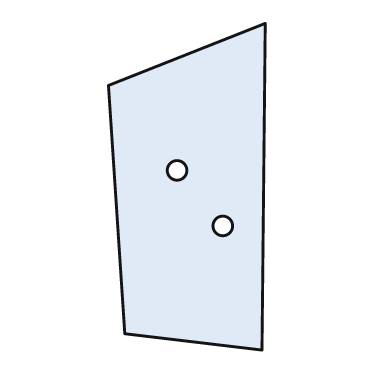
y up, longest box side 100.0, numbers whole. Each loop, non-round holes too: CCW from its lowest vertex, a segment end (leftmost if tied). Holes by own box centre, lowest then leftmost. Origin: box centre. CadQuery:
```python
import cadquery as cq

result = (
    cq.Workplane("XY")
    .moveTo(23.0, -50.0)
    .lineTo(24.0, 50.0)
    .lineTo(-24.0, 31.0)
    .lineTo(-19.0, -45.0)
    .close()
    .moveTo(11.0, -12.0)
    .circle(3.0)
    .moveTo(-3.0, 5.0)
    .circle(3.0)
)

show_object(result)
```